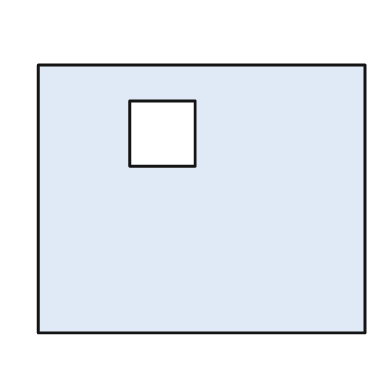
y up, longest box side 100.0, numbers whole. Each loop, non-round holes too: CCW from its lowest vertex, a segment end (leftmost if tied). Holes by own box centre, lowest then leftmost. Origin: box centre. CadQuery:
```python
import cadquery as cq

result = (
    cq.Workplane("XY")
    .moveTo(-50.0, -41.0)
    .lineTo(50.0, -41.0)
    .lineTo(50.0, 41.0)
    .lineTo(-50.0, 41.0)
    .close()
    .moveTo(-22.0, 10.0)
    .lineTo(-2.0, 10.0)
    .lineTo(-2.0, 30.0)
    .lineTo(-22.0, 30.0)
    .close()
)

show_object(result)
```